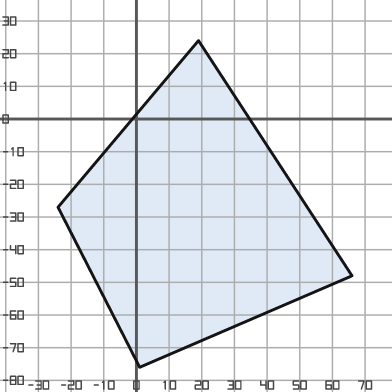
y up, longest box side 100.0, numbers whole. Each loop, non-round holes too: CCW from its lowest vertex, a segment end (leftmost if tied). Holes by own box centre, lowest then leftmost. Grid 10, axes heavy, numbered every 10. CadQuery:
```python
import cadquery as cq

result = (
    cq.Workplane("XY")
    .moveTo(1.0, -76.0)
    .lineTo(66.0, -48.0)
    .lineTo(19.0, 24.0)
    .lineTo(-24.0, -27.0)
    .close()
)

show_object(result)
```